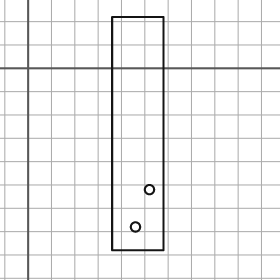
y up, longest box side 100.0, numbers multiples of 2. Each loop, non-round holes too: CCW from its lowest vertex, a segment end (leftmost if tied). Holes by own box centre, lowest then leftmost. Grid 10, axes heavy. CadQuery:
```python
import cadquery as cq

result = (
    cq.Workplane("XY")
    .moveTo(36.0, -78.0)
    .lineTo(58.0, -78.0)
    .lineTo(58.0, 22.0)
    .lineTo(36.0, 22.0)
    .close()
    .moveTo(46.0, -68.0)
    .circle(2.0)
    .moveTo(52.0, -52.0)
    .circle(2.0)
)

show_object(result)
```